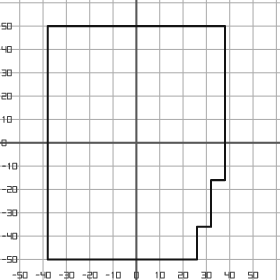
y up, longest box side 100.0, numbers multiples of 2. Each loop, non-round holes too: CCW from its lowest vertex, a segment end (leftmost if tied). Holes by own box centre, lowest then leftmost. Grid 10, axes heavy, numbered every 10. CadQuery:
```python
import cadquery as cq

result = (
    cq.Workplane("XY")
    .moveTo(-38.0, -50.0)
    .lineTo(26.0, -50.0)
    .lineTo(26.0, -36.0)
    .lineTo(32.0, -36.0)
    .lineTo(32.0, -16.0)
    .lineTo(38.0, -16.0)
    .lineTo(38.0, 50.0)
    .lineTo(-38.0, 50.0)
    .close()
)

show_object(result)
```